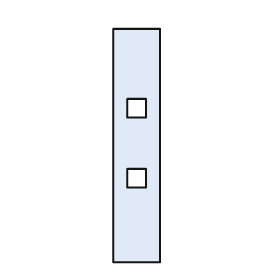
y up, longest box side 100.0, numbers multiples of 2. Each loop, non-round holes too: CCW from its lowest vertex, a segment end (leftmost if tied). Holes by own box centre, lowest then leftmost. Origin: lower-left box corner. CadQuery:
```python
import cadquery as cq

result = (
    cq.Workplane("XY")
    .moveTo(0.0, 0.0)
    .lineTo(20.0, 0.0)
    .lineTo(20.0, 100.0)
    .lineTo(0.0, 100.0)
    .close()
    .moveTo(6.0, 32.0)
    .lineTo(14.0, 32.0)
    .lineTo(14.0, 40.0)
    .lineTo(6.0, 40.0)
    .close()
    .moveTo(6.0, 62.0)
    .lineTo(14.0, 62.0)
    .lineTo(14.0, 70.0)
    .lineTo(6.0, 70.0)
    .close()
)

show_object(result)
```